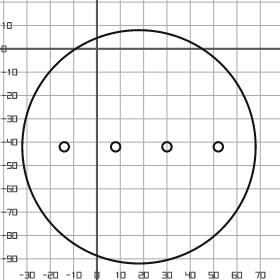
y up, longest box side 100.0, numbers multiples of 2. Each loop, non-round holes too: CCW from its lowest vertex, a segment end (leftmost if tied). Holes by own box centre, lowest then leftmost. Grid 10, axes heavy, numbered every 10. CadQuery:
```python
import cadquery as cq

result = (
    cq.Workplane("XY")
    .moveTo(18.0, -42.0)
    .circle(50.0)
    .moveTo(-14.0, -42.0)
    .circle(2.0)
    .moveTo(8.0, -42.0)
    .circle(2.0)
    .moveTo(30.0, -42.0)
    .circle(2.0)
    .moveTo(52.0, -42.0)
    .circle(2.0)
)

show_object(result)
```